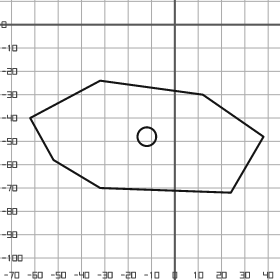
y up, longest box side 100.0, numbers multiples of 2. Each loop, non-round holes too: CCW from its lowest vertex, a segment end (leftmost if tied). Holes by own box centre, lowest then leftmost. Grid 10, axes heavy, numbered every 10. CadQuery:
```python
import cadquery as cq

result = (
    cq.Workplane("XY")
    .moveTo(24.0, -72.0)
    .lineTo(38.0, -48.0)
    .lineTo(12.0, -30.0)
    .lineTo(-32.0, -24.0)
    .lineTo(-62.0, -40.0)
    .lineTo(-52.0, -58.0)
    .lineTo(-32.0, -70.0)
    .close()
    .moveTo(-12.0, -48.0)
    .circle(4.0)
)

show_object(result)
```